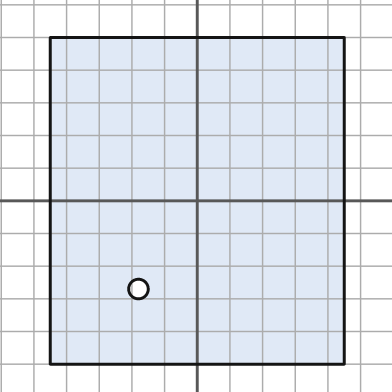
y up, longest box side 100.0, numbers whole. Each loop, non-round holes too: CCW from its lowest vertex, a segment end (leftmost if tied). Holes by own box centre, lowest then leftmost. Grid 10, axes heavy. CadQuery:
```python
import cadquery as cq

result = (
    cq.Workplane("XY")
    .moveTo(-45.0, -50.0)
    .lineTo(45.0, -50.0)
    .lineTo(45.0, 50.0)
    .lineTo(-45.0, 50.0)
    .close()
    .moveTo(-18.0, -27.0)
    .circle(3.0)
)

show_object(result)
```